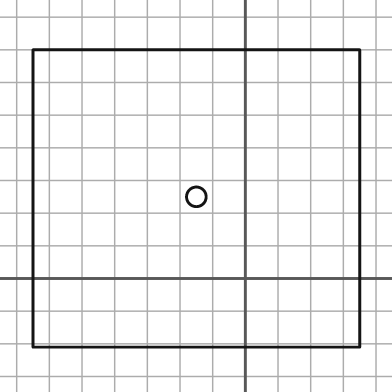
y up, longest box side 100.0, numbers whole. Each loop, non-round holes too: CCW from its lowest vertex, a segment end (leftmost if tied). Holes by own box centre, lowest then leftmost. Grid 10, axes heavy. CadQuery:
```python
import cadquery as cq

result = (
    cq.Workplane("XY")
    .moveTo(-65.0, -21.0)
    .lineTo(35.0, -21.0)
    .lineTo(35.0, 70.0)
    .lineTo(-65.0, 70.0)
    .close()
    .moveTo(-15.0, 25.0)
    .circle(3.0)
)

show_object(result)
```